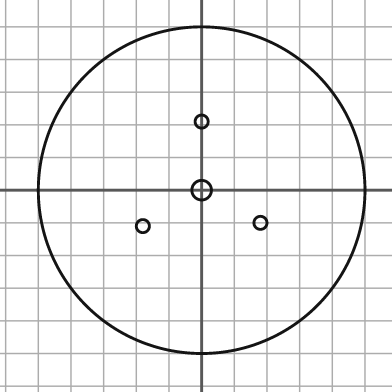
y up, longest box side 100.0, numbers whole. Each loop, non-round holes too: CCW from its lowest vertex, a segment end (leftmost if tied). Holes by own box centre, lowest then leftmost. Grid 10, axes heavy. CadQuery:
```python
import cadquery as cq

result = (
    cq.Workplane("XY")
    .moveTo(0.0, 0.0)
    .circle(50.0)
    .moveTo(-18.0, -11.0)
    .circle(2.0)
    .moveTo(18.0, -10.0)
    .circle(2.0)
    .moveTo(0.0, 0.0)
    .circle(3.0)
    .moveTo(0.0, 21.0)
    .circle(2.0)
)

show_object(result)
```